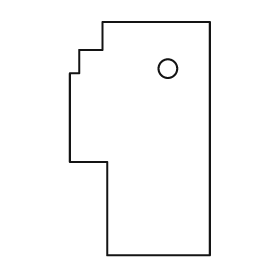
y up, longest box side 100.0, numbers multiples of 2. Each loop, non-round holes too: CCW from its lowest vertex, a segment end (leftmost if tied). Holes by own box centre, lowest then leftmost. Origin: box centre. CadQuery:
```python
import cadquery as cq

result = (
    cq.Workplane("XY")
    .moveTo(-14.0, -50.0)
    .lineTo(30.0, -50.0)
    .lineTo(30.0, 50.0)
    .lineTo(-16.0, 50.0)
    .lineTo(-16.0, 38.0)
    .lineTo(-26.0, 38.0)
    .lineTo(-26.0, 28.0)
    .lineTo(-30.0, 28.0)
    .lineTo(-30.0, -10.0)
    .lineTo(-14.0, -10.0)
    .close()
    .moveTo(12.0, 30.0)
    .circle(4.0)
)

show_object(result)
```